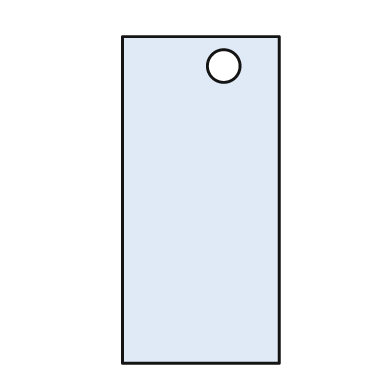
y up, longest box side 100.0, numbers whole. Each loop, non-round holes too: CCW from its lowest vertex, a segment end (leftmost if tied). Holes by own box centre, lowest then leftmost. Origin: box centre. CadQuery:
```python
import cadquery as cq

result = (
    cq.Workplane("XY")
    .moveTo(-24.0, -50.0)
    .lineTo(24.0, -50.0)
    .lineTo(24.0, 50.0)
    .lineTo(-24.0, 50.0)
    .close()
    .moveTo(7.0, 41.0)
    .circle(5.0)
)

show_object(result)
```